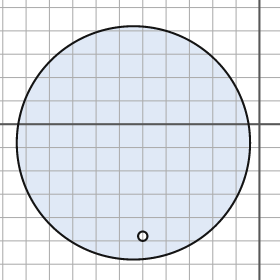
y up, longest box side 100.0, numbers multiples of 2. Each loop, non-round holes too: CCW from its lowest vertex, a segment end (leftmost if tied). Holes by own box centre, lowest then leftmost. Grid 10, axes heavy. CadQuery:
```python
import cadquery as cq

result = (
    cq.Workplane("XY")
    .moveTo(-54.0, -8.0)
    .circle(50.0)
    .moveTo(-50.0, -48.0)
    .circle(2.0)
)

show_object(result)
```